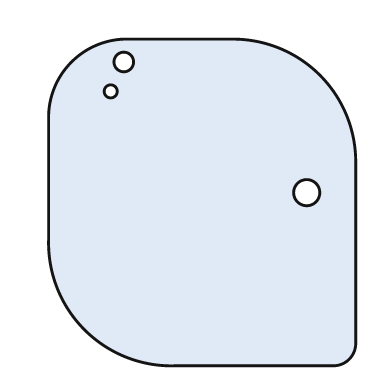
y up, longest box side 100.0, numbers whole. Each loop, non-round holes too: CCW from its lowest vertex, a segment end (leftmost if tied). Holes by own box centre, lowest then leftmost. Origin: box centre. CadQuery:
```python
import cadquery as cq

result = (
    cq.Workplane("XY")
    .moveTo(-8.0, -50.0)
    .lineTo(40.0, -50.0)
    .threePointArc((45.0, -48.0), (47.0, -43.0))
    .lineTo(47.0, 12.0)
    .threePointArc((36.0, 39.0), (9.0, 50.0))
    .lineTo(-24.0, 50.0)
    .threePointArc((-40.0, 43.0), (-47.0, 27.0))
    .lineTo(-47.0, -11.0)
    .threePointArc((-36.0, -39.0), (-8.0, -50.0))
    .close()
    .moveTo(32.0, 3.0)
    .circle(4.0)
    .moveTo(-28.0, 34.0)
    .circle(2.0)
    .moveTo(-24.0, 43.0)
    .circle(3.0)
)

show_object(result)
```